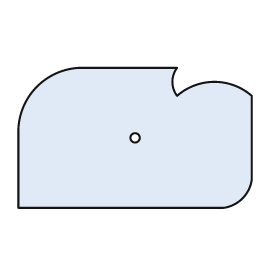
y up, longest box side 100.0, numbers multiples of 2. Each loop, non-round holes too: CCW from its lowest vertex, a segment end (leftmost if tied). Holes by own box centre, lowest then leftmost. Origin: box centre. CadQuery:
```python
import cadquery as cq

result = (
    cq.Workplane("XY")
    .moveTo(-50.0, -30.0)
    .lineTo(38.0, -30.0)
    .threePointArc((46.0, -26.0), (50.0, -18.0))
    .lineTo(50.0, 18.0)
    .threePointArc((34.0, 24.0), (18.0, 18.0))
    .threePointArc((16.0, 24.0), (18.0, 30.0))
    .lineTo(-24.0, 30.0)
    .threePointArc((-42.0, 22.0), (-50.0, 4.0))
    .close()
    .moveTo(0.0, 0.0)
    .circle(2.0)
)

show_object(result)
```